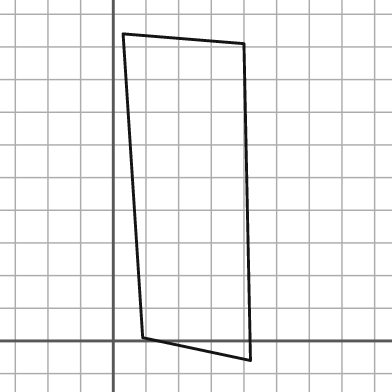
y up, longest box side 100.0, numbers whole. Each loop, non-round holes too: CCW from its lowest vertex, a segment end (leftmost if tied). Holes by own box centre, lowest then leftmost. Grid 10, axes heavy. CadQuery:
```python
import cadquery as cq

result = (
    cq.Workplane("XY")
    .moveTo(42.0, -6.0)
    .lineTo(40.0, 91.0)
    .lineTo(3.0, 94.0)
    .lineTo(9.0, 1.0)
    .close()
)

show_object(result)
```